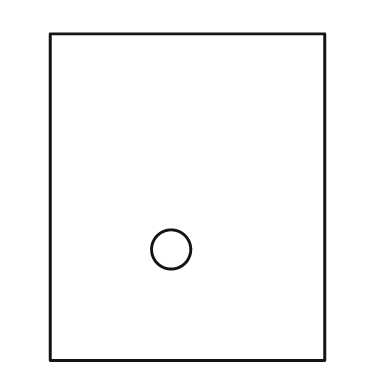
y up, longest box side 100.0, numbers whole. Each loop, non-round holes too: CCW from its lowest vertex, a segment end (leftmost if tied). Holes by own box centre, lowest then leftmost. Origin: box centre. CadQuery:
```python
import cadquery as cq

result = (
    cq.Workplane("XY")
    .moveTo(-42.0, -50.0)
    .lineTo(42.0, -50.0)
    .lineTo(42.0, 50.0)
    .lineTo(-42.0, 50.0)
    .close()
    .moveTo(-5.0, -16.0)
    .circle(6.0)
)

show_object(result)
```